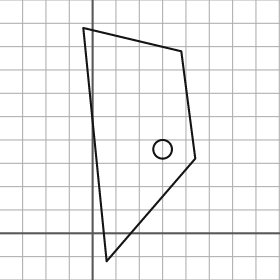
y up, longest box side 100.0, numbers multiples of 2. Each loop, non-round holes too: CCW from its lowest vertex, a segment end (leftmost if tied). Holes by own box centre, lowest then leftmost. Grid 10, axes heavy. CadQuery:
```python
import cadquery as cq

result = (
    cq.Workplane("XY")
    .moveTo(6.0, -12.0)
    .lineTo(44.0, 32.0)
    .lineTo(38.0, 78.0)
    .lineTo(-4.0, 88.0)
    .close()
    .moveTo(30.0, 36.0)
    .circle(4.0)
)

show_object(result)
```